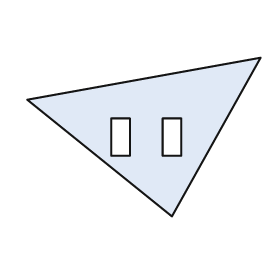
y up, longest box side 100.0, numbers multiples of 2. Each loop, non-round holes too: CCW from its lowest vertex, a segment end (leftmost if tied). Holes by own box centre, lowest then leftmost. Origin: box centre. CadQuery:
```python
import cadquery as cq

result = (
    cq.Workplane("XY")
    .moveTo(12.0, -34.0)
    .lineTo(50.0, 34.0)
    .lineTo(-50.0, 16.0)
    .close()
    .moveTo(-14.0, -8.0)
    .lineTo(-6.0, -8.0)
    .lineTo(-6.0, 8.0)
    .lineTo(-14.0, 8.0)
    .close()
    .moveTo(8.0, -8.0)
    .lineTo(16.0, -8.0)
    .lineTo(16.0, 8.0)
    .lineTo(8.0, 8.0)
    .close()
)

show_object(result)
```